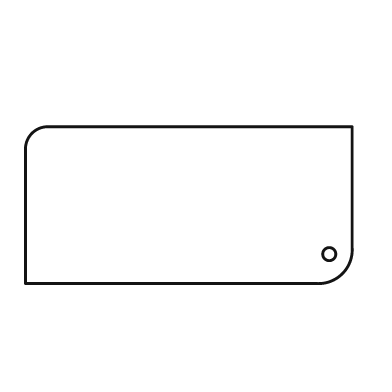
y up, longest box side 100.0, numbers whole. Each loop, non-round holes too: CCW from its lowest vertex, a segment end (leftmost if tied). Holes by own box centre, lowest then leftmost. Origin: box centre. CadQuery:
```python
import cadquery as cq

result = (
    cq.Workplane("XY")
    .moveTo(-50.0, -24.0)
    .lineTo(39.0, -24.0)
    .threePointArc((47.0, -21.0), (50.0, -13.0))
    .lineTo(50.0, 24.0)
    .lineTo(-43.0, 24.0)
    .threePointArc((-48.0, 22.0), (-50.0, 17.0))
    .close()
    .moveTo(43.0, -15.0)
    .circle(2.0)
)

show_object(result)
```